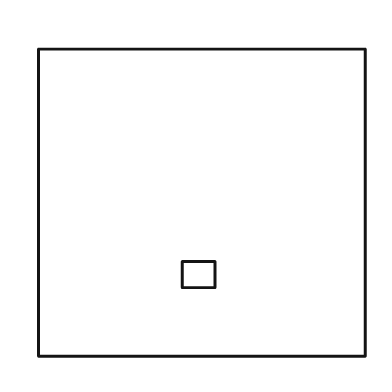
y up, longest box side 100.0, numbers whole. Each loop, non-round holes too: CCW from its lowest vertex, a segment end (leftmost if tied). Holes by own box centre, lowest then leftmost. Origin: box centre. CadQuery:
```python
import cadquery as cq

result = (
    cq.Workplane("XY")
    .moveTo(-50.0, -47.0)
    .lineTo(50.0, -47.0)
    .lineTo(50.0, 47.0)
    .lineTo(-50.0, 47.0)
    .close()
    .moveTo(-6.0, -26.0)
    .lineTo(4.0, -26.0)
    .lineTo(4.0, -18.0)
    .lineTo(-6.0, -18.0)
    .close()
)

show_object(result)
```